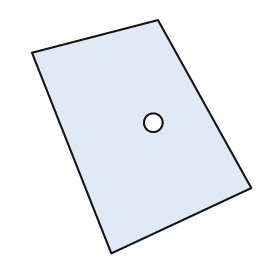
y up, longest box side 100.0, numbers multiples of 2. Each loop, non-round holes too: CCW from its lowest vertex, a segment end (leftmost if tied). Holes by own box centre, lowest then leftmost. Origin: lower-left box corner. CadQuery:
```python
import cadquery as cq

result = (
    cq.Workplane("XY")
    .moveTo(34.0, 0.0)
    .lineTo(94.0, 28.0)
    .lineTo(54.0, 100.0)
    .lineTo(0.0, 86.0)
    .close()
    .moveTo(52.0, 56.0)
    .circle(4.0)
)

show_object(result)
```